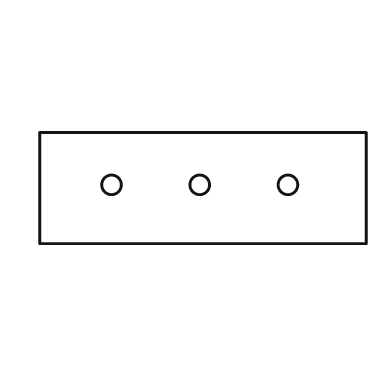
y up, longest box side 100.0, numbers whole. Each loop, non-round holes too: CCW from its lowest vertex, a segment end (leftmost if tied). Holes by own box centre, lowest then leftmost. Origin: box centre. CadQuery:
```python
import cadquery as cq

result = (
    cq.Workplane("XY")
    .moveTo(-50.0, -17.0)
    .lineTo(50.0, -17.0)
    .lineTo(50.0, 17.0)
    .lineTo(-50.0, 17.0)
    .close()
    .moveTo(-28.0, 1.0)
    .circle(3.0)
    .moveTo(-1.0, 1.0)
    .circle(3.0)
    .moveTo(26.0, 1.0)
    .circle(3.0)
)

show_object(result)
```